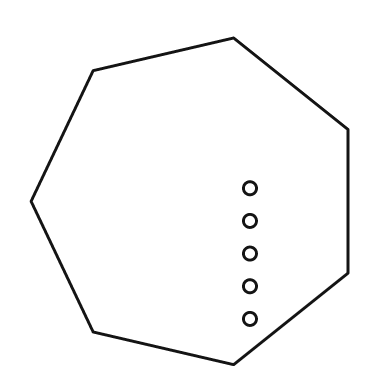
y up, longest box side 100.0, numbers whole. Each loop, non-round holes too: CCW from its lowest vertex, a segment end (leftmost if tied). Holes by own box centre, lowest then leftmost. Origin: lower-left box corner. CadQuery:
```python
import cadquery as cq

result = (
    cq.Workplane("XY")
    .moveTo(62.0, 0.0)
    .lineTo(97.0, 28.0)
    .lineTo(97.0, 72.0)
    .lineTo(62.0, 100.0)
    .lineTo(19.0, 90.0)
    .lineTo(0.0, 50.0)
    .lineTo(19.0, 10.0)
    .close()
    .moveTo(67.0, 14.0)
    .circle(2.0)
    .moveTo(67.0, 24.0)
    .circle(2.0)
    .moveTo(67.0, 34.0)
    .circle(2.0)
    .moveTo(67.0, 44.0)
    .circle(2.0)
    .moveTo(67.0, 54.0)
    .circle(2.0)
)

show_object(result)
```